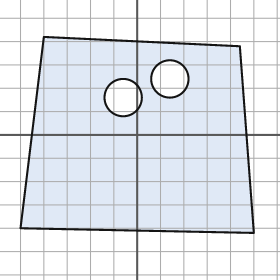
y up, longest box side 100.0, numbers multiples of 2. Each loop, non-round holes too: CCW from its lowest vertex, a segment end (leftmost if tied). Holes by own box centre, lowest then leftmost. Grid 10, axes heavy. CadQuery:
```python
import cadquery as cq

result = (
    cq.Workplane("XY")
    .moveTo(50.0, -42.0)
    .lineTo(44.0, 38.0)
    .lineTo(-40.0, 42.0)
    .lineTo(-50.0, -40.0)
    .close()
    .moveTo(-6.0, 16.0)
    .circle(8.0)
    .moveTo(14.0, 24.0)
    .circle(8.0)
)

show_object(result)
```